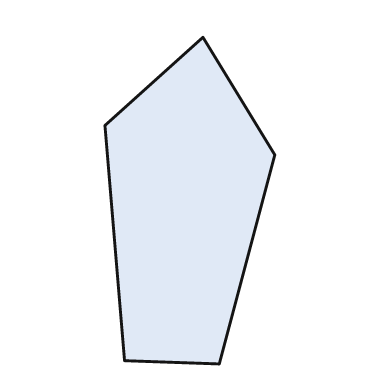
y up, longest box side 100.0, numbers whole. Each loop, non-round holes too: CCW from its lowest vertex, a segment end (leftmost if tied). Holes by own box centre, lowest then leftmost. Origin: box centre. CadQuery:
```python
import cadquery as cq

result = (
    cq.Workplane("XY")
    .moveTo(9.0, -50.0)
    .lineTo(26.0, 14.0)
    .lineTo(4.0, 50.0)
    .lineTo(-26.0, 23.0)
    .lineTo(-20.0, -49.0)
    .close()
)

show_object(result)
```